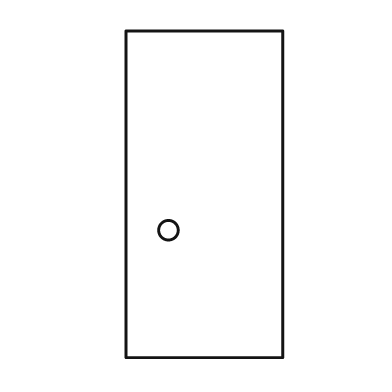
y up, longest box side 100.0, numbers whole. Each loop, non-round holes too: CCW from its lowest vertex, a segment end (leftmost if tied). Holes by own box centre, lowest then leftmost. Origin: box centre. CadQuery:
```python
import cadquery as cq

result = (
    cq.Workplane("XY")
    .moveTo(-24.0, -50.0)
    .lineTo(24.0, -50.0)
    .lineTo(24.0, 50.0)
    .lineTo(-24.0, 50.0)
    .close()
    .moveTo(-11.0, -11.0)
    .circle(3.0)
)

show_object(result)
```